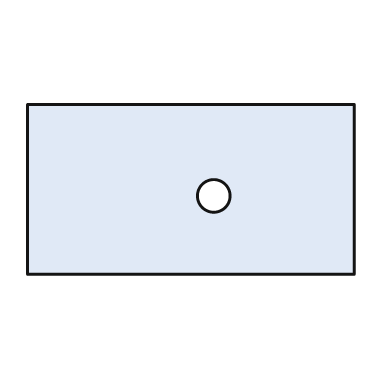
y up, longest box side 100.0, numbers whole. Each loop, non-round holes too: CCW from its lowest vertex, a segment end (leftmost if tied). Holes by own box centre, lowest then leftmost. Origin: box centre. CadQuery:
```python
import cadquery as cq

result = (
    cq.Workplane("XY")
    .moveTo(-50.0, -26.0)
    .lineTo(50.0, -26.0)
    .lineTo(50.0, 26.0)
    .lineTo(-50.0, 26.0)
    .close()
    .moveTo(7.0, -2.0)
    .circle(5.0)
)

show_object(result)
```